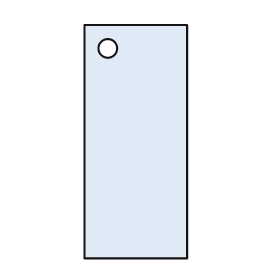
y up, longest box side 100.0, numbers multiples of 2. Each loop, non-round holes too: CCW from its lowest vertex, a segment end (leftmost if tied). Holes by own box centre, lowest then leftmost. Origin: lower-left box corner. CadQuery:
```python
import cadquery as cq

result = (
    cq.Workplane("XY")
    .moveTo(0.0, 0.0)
    .lineTo(44.0, 0.0)
    .lineTo(44.0, 100.0)
    .lineTo(0.0, 100.0)
    .close()
    .moveTo(10.0, 90.0)
    .circle(4.0)
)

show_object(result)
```